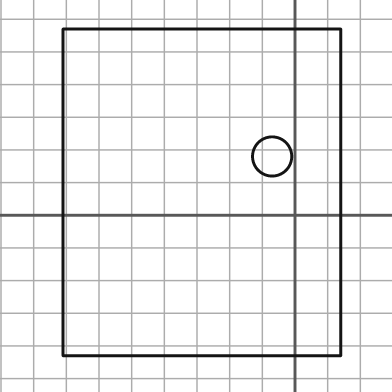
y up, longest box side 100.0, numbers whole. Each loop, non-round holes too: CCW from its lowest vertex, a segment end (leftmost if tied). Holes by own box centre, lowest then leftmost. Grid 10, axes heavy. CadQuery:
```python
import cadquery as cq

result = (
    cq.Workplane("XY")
    .moveTo(-71.0, -43.0)
    .lineTo(14.0, -43.0)
    .lineTo(14.0, 57.0)
    .lineTo(-71.0, 57.0)
    .close()
    .moveTo(-7.0, 18.0)
    .circle(6.0)
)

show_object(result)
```